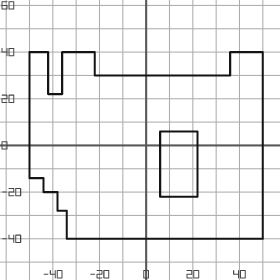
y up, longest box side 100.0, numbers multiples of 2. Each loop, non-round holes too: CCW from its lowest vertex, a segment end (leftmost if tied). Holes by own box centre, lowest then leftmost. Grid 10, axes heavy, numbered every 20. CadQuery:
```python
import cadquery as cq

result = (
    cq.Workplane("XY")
    .moveTo(-34.0, -40.0)
    .lineTo(50.0, -40.0)
    .lineTo(50.0, 40.0)
    .lineTo(36.0, 40.0)
    .lineTo(36.0, 30.0)
    .lineTo(-22.0, 30.0)
    .lineTo(-22.0, 40.0)
    .lineTo(-36.0, 40.0)
    .lineTo(-36.0, 22.0)
    .lineTo(-42.0, 22.0)
    .lineTo(-42.0, 40.0)
    .lineTo(-50.0, 40.0)
    .lineTo(-50.0, -14.0)
    .lineTo(-44.0, -14.0)
    .lineTo(-44.0, -20.0)
    .lineTo(-38.0, -20.0)
    .lineTo(-38.0, -28.0)
    .lineTo(-34.0, -28.0)
    .close()
    .moveTo(6.0, -22.0)
    .lineTo(22.0, -22.0)
    .lineTo(22.0, 6.0)
    .lineTo(6.0, 6.0)
    .close()
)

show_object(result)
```